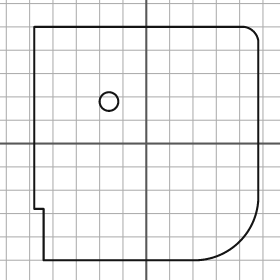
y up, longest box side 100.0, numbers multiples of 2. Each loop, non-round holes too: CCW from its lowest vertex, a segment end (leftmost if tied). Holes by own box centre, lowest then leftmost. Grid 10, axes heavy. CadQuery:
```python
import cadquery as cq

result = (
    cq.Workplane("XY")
    .moveTo(-44.0, -50.0)
    .lineTo(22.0, -50.0)
    .threePointArc((40.0, -42.0), (48.0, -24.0))
    .lineTo(48.0, 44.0)
    .threePointArc((46.0, 48.0), (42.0, 50.0))
    .lineTo(-48.0, 50.0)
    .lineTo(-48.0, -28.0)
    .lineTo(-44.0, -28.0)
    .close()
    .moveTo(-16.0, 18.0)
    .circle(4.0)
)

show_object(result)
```